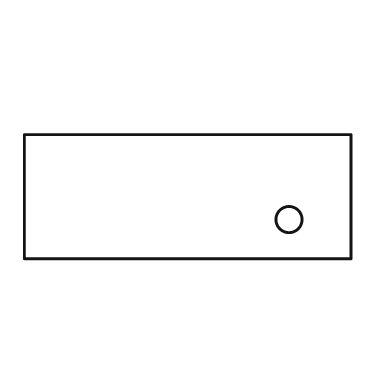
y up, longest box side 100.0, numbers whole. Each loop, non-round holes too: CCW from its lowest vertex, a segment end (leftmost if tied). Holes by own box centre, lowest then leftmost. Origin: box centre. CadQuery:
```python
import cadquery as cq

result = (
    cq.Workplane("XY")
    .moveTo(-50.0, -19.0)
    .lineTo(50.0, -19.0)
    .lineTo(50.0, 19.0)
    .lineTo(-50.0, 19.0)
    .close()
    .moveTo(31.0, -7.0)
    .circle(4.0)
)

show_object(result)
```